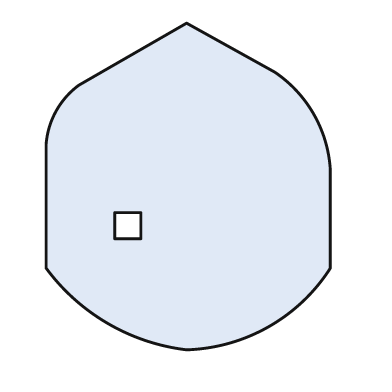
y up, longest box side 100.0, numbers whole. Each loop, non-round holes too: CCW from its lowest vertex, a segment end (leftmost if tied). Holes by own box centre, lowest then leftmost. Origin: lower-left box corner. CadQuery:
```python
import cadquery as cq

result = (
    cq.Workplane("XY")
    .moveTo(43.0, 0.0)
    .threePointArc((68.0, 7.0), (87.0, 25.0))
    .lineTo(87.0, 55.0)
    .threePointArc((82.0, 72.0), (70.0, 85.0))
    .lineTo(43.0, 100.0)
    .lineTo(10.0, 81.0)
    .threePointArc((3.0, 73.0), (0.0, 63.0))
    .lineTo(0.0, 25.0)
    .threePointArc((19.0, 8.0), (43.0, 0.0))
    .close()
    .moveTo(21.0, 34.0)
    .lineTo(29.0, 34.0)
    .lineTo(29.0, 42.0)
    .lineTo(21.0, 42.0)
    .close()
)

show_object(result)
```